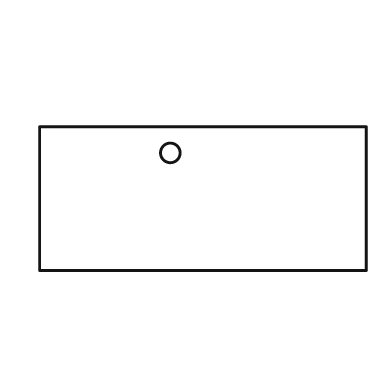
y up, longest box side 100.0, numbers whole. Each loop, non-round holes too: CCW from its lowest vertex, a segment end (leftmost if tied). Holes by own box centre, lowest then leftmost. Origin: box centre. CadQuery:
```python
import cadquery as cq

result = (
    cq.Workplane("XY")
    .moveTo(-50.0, -22.0)
    .lineTo(50.0, -22.0)
    .lineTo(50.0, 22.0)
    .lineTo(-50.0, 22.0)
    .close()
    .moveTo(-10.0, 14.0)
    .circle(3.0)
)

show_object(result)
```